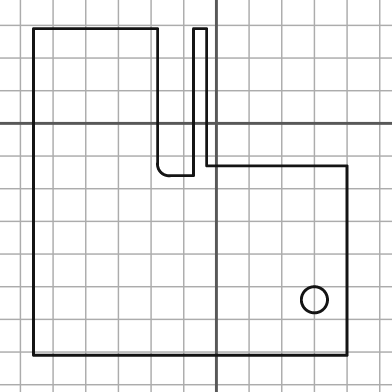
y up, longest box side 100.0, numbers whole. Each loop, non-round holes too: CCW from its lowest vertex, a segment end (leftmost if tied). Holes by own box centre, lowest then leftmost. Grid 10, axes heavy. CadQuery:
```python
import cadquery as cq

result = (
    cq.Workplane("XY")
    .moveTo(-56.0, -71.0)
    .lineTo(40.0, -71.0)
    .lineTo(40.0, -13.0)
    .lineTo(-3.0, -13.0)
    .lineTo(-3.0, 29.0)
    .lineTo(-7.0, 29.0)
    .lineTo(-7.0, -16.0)
    .lineTo(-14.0, -16.0)
    .threePointArc((-17.0, -15.0), (-18.0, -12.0))
    .lineTo(-18.0, 29.0)
    .lineTo(-56.0, 29.0)
    .close()
    .moveTo(30.0, -54.0)
    .circle(4.0)
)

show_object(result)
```